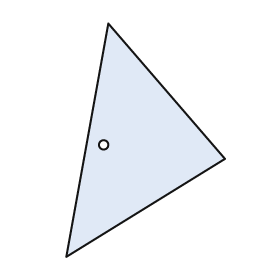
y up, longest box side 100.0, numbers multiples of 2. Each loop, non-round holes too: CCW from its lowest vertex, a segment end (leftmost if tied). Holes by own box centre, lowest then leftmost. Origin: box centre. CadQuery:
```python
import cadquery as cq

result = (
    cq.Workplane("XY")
    .moveTo(-34.0, -50.0)
    .lineTo(34.0, -8.0)
    .lineTo(-16.0, 50.0)
    .close()
    .moveTo(-18.0, -2.0)
    .circle(2.0)
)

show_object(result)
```